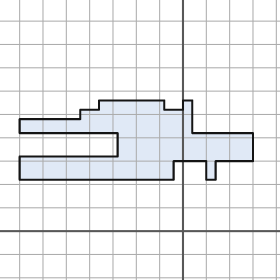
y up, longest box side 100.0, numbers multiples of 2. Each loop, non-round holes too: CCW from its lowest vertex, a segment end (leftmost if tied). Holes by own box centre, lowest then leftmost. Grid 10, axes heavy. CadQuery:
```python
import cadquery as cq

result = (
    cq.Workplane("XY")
    .moveTo(-70.0, 22.0)
    .lineTo(-4.0, 22.0)
    .lineTo(-4.0, 30.0)
    .lineTo(10.0, 30.0)
    .lineTo(10.0, 22.0)
    .lineTo(14.0, 22.0)
    .lineTo(14.0, 30.0)
    .lineTo(30.0, 30.0)
    .lineTo(30.0, 42.0)
    .lineTo(4.0, 42.0)
    .lineTo(4.0, 56.0)
    .lineTo(0.0, 56.0)
    .lineTo(0.0, 52.0)
    .lineTo(-8.0, 52.0)
    .lineTo(-8.0, 56.0)
    .lineTo(-36.0, 56.0)
    .lineTo(-36.0, 52.0)
    .lineTo(-44.0, 52.0)
    .lineTo(-44.0, 48.0)
    .lineTo(-70.0, 48.0)
    .lineTo(-70.0, 42.0)
    .lineTo(-28.0, 42.0)
    .lineTo(-28.0, 32.0)
    .lineTo(-70.0, 32.0)
    .close()
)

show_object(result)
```